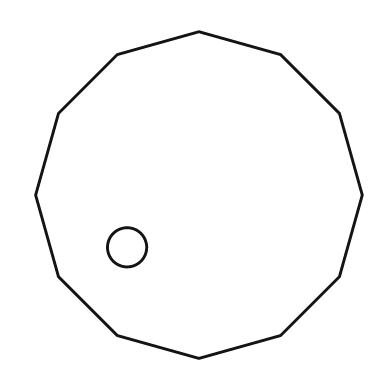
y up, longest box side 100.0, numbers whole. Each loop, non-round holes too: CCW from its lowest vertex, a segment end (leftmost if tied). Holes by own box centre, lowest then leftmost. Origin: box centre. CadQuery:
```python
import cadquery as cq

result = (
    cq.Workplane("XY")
    .moveTo(0.0, -50.0)
    .lineTo(25.0, -43.0)
    .lineTo(43.0, -25.0)
    .lineTo(50.0, 0.0)
    .lineTo(43.0, 25.0)
    .lineTo(25.0, 43.0)
    .lineTo(0.0, 50.0)
    .lineTo(-25.0, 43.0)
    .lineTo(-43.0, 25.0)
    .lineTo(-50.0, 0.0)
    .lineTo(-43.0, -25.0)
    .lineTo(-25.0, -43.0)
    .close()
    .moveTo(-22.0, -16.0)
    .circle(6.0)
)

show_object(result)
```